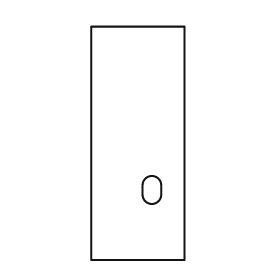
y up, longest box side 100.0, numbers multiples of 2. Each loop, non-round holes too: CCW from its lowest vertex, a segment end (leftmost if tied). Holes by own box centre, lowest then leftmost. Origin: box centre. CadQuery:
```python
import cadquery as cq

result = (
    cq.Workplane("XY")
    .moveTo(-20.0, -50.0)
    .lineTo(20.0, -50.0)
    .lineTo(20.0, 50.0)
    .lineTo(-20.0, 50.0)
    .close()
    .moveTo(2.0, -22.0)
    .threePointArc((6.0, -26.0), (10.0, -22.0))
    .lineTo(10.0, -18.0)
    .threePointArc((6.0, -14.0), (2.0, -18.0))
    .close()
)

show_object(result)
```